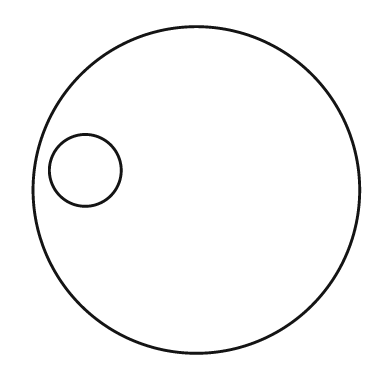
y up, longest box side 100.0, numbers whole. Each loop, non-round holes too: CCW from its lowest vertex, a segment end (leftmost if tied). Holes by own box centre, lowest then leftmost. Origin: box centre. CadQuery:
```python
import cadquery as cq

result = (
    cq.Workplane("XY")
    .moveTo(0.0, 0.0)
    .circle(50.0)
    .moveTo(-34.0, 6.0)
    .circle(11.0)
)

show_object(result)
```